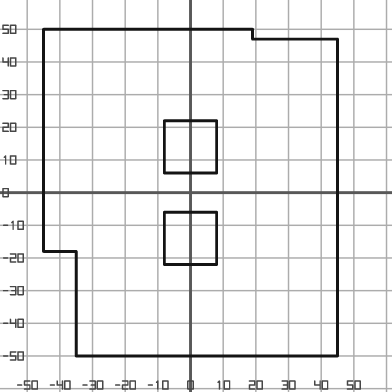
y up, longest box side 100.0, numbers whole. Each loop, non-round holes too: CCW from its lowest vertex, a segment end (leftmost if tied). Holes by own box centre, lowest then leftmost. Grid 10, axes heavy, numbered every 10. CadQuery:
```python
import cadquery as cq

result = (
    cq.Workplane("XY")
    .moveTo(-35.0, -50.0)
    .lineTo(45.0, -50.0)
    .lineTo(45.0, 47.0)
    .lineTo(19.0, 47.0)
    .lineTo(19.0, 50.0)
    .lineTo(-45.0, 50.0)
    .lineTo(-45.0, -18.0)
    .lineTo(-35.0, -18.0)
    .close()
    .moveTo(-8.0, -22.0)
    .lineTo(8.0, -22.0)
    .lineTo(8.0, -6.0)
    .lineTo(-8.0, -6.0)
    .close()
    .moveTo(-8.0, 6.0)
    .lineTo(8.0, 6.0)
    .lineTo(8.0, 22.0)
    .lineTo(-8.0, 22.0)
    .close()
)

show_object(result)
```